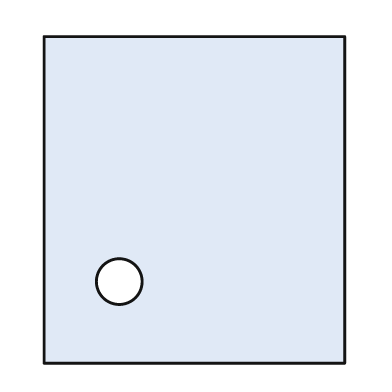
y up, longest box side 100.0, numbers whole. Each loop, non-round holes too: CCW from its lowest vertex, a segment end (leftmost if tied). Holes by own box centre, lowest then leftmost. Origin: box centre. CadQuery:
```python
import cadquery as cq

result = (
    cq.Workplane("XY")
    .moveTo(-46.0, -50.0)
    .lineTo(46.0, -50.0)
    .lineTo(46.0, 50.0)
    .lineTo(-46.0, 50.0)
    .close()
    .moveTo(-23.0, -25.0)
    .circle(7.0)
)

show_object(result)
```